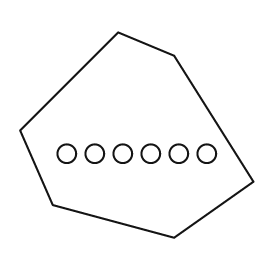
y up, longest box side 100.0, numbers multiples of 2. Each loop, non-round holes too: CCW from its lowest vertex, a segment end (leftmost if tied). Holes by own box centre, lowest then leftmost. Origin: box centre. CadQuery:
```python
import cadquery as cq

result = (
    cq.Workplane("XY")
    .moveTo(16.0, -44.0)
    .lineTo(50.0, -20.0)
    .lineTo(16.0, 34.0)
    .lineTo(-8.0, 44.0)
    .lineTo(-50.0, 2.0)
    .lineTo(-36.0, -30.0)
    .close()
    .moveTo(-30.0, -8.0)
    .circle(4.0)
    .moveTo(-18.0, -8.0)
    .circle(4.0)
    .moveTo(-6.0, -8.0)
    .circle(4.0)
    .moveTo(6.0, -8.0)
    .circle(4.0)
    .moveTo(18.0, -8.0)
    .circle(4.0)
    .moveTo(30.0, -8.0)
    .circle(4.0)
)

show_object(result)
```